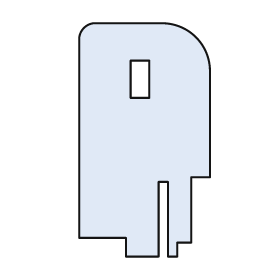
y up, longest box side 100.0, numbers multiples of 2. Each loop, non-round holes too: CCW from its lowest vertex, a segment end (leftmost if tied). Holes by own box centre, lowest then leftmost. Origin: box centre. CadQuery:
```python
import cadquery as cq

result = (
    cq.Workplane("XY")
    .moveTo(-8.0, -50.0)
    .lineTo(6.0, -50.0)
    .lineTo(6.0, -18.0)
    .lineTo(10.0, -18.0)
    .lineTo(10.0, -50.0)
    .lineTo(14.0, -50.0)
    .lineTo(14.0, -44.0)
    .lineTo(20.0, -44.0)
    .lineTo(20.0, -16.0)
    .lineTo(28.0, -16.0)
    .lineTo(28.0, 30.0)
    .threePointArc((22.0, 44.0), (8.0, 50.0))
    .lineTo(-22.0, 50.0)
    .threePointArc((-26.0, 48.0), (-28.0, 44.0))
    .lineTo(-28.0, -42.0)
    .lineTo(-8.0, -42.0)
    .close()
    .moveTo(-6.0, 18.0)
    .lineTo(2.0, 18.0)
    .lineTo(2.0, 34.0)
    .lineTo(-6.0, 34.0)
    .close()
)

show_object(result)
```